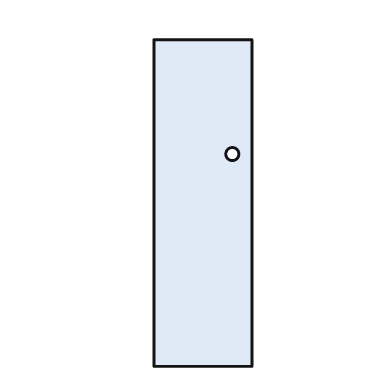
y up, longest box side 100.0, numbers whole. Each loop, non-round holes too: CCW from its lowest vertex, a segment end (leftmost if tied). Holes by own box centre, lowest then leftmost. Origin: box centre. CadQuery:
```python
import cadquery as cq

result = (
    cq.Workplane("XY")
    .moveTo(-15.0, -50.0)
    .lineTo(15.0, -50.0)
    .lineTo(15.0, 50.0)
    .lineTo(-15.0, 50.0)
    .close()
    .moveTo(9.0, 15.0)
    .circle(2.0)
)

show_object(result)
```